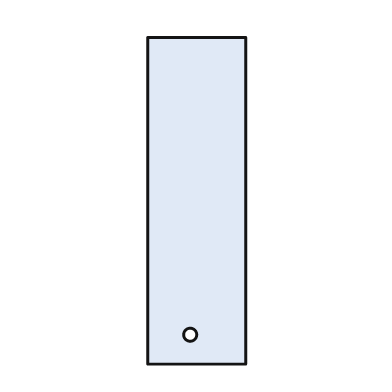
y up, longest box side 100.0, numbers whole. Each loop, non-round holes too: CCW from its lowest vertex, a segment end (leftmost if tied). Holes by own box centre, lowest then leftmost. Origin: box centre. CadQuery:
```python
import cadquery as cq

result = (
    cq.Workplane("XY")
    .moveTo(-15.0, -50.0)
    .lineTo(15.0, -50.0)
    .lineTo(15.0, 50.0)
    .lineTo(-15.0, 50.0)
    .close()
    .moveTo(-2.0, -41.0)
    .circle(2.0)
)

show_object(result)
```